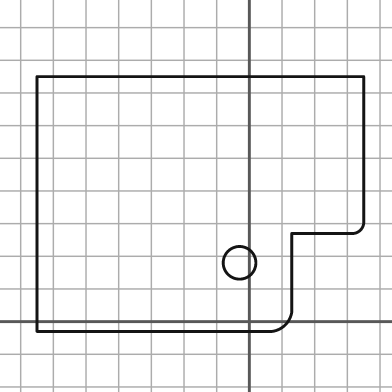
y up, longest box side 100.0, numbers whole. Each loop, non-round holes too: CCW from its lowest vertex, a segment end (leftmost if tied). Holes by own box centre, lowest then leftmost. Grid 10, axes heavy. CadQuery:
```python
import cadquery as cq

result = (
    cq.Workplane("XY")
    .moveTo(-65.0, -3.0)
    .lineTo(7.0, -3.0)
    .threePointArc((11.0, -1.0), (13.0, 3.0))
    .lineTo(13.0, 27.0)
    .lineTo(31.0, 27.0)
    .threePointArc((34.0, 28.0), (35.0, 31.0))
    .lineTo(35.0, 75.0)
    .lineTo(-65.0, 75.0)
    .close()
    .moveTo(-3.0, 18.0)
    .circle(5.0)
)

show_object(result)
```